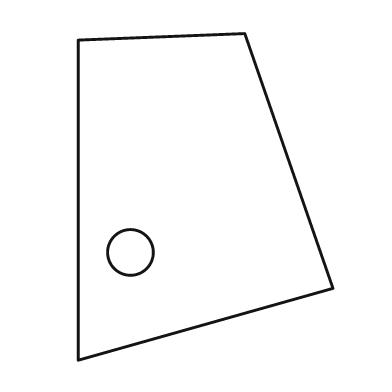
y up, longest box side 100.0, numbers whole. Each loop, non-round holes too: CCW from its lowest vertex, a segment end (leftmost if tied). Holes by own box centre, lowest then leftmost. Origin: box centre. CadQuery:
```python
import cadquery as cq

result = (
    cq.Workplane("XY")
    .moveTo(-39.0, -50.0)
    .lineTo(39.0, -28.0)
    .lineTo(12.0, 50.0)
    .lineTo(-39.0, 48.0)
    .close()
    .moveTo(-23.0, -17.0)
    .circle(7.0)
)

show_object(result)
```